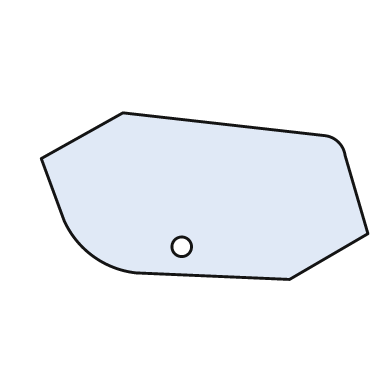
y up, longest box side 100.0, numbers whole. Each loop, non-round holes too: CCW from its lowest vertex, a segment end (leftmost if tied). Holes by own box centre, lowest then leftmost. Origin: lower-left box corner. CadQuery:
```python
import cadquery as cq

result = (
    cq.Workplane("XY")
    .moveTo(76.0, 0.0)
    .lineTo(100.0, 14.0)
    .lineTo(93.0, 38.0)
    .threePointArc((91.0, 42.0), (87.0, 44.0))
    .lineTo(25.0, 51.0)
    .lineTo(0.0, 37.0)
    .lineTo(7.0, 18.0)
    .threePointArc((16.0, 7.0), (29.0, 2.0))
    .close()
    .moveTo(43.0, 10.0)
    .circle(3.0)
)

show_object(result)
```